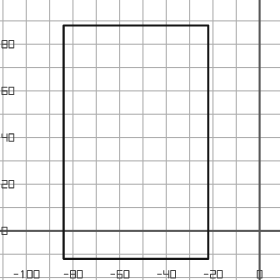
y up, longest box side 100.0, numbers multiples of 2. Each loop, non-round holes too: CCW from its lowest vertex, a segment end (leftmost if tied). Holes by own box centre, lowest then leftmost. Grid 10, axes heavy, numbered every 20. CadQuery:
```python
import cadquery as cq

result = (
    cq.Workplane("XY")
    .moveTo(-84.0, -12.0)
    .lineTo(-22.0, -12.0)
    .lineTo(-22.0, 88.0)
    .lineTo(-84.0, 88.0)
    .close()
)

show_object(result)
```